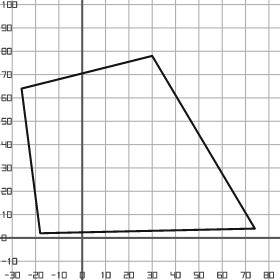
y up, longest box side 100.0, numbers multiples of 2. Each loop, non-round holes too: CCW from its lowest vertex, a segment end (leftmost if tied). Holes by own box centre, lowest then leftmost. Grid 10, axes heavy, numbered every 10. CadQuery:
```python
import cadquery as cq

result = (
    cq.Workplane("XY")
    .moveTo(-18.0, 2.0)
    .lineTo(74.0, 4.0)
    .lineTo(30.0, 78.0)
    .lineTo(-26.0, 64.0)
    .close()
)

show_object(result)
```